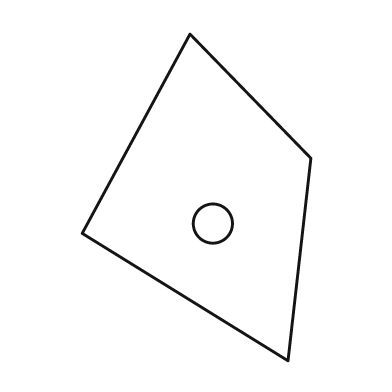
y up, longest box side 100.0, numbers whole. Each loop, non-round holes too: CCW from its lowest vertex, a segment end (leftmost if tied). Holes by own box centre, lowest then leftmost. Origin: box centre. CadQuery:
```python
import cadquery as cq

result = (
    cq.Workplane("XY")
    .moveTo(28.0, -50.0)
    .lineTo(35.0, 12.0)
    .lineTo(-2.0, 50.0)
    .lineTo(-35.0, -11.0)
    .close()
    .moveTo(5.0, -8.0)
    .circle(6.0)
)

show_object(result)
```